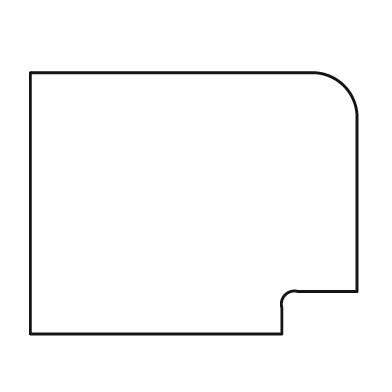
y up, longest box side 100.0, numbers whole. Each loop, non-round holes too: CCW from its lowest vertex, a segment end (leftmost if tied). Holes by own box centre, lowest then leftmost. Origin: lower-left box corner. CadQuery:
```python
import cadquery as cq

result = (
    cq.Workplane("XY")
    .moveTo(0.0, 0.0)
    .lineTo(77.0, 0.0)
    .lineTo(77.0, 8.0)
    .threePointArc((78.0, 12.0), (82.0, 13.0))
    .lineTo(100.0, 13.0)
    .lineTo(100.0, 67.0)
    .threePointArc((96.0, 76.0), (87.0, 80.0))
    .lineTo(0.0, 80.0)
    .close()
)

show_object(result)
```